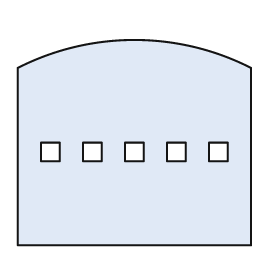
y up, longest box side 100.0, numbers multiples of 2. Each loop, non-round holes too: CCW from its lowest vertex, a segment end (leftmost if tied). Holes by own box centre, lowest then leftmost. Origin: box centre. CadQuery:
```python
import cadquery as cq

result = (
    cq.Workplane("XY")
    .moveTo(-50.0, -44.0)
    .lineTo(50.0, -44.0)
    .lineTo(50.0, 32.0)
    .threePointArc((0.0, 44.0), (-50.0, 32.0))
    .close()
    .moveTo(-40.0, -8.0)
    .lineTo(-32.0, -8.0)
    .lineTo(-32.0, 0.0)
    .lineTo(-40.0, 0.0)
    .close()
    .moveTo(-22.0, -8.0)
    .lineTo(-14.0, -8.0)
    .lineTo(-14.0, 0.0)
    .lineTo(-22.0, 0.0)
    .close()
    .moveTo(-4.0, -8.0)
    .lineTo(4.0, -8.0)
    .lineTo(4.0, 0.0)
    .lineTo(-4.0, 0.0)
    .close()
    .moveTo(14.0, -8.0)
    .lineTo(22.0, -8.0)
    .lineTo(22.0, 0.0)
    .lineTo(14.0, 0.0)
    .close()
    .moveTo(32.0, -8.0)
    .lineTo(40.0, -8.0)
    .lineTo(40.0, 0.0)
    .lineTo(32.0, 0.0)
    .close()
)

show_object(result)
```